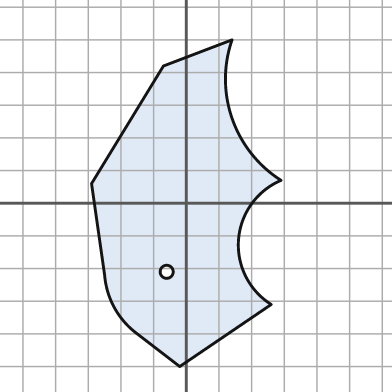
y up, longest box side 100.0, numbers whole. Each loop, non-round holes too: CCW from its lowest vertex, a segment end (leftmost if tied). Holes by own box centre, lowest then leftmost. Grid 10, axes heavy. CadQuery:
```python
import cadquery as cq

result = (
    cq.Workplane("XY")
    .moveTo(-2.0, -50.0)
    .lineTo(26.0, -31.0)
    .threePointArc((16.0, -11.0), (29.0, 7.0))
    .threePointArc((14.0, 26.0), (14.0, 50.0))
    .lineTo(-7.0, 42.0)
    .lineTo(-29.0, 6.0)
    .lineTo(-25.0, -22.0)
    .threePointArc((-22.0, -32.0), (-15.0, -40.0))
    .close()
    .moveTo(-6.0, -21.0)
    .circle(2.0)
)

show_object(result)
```